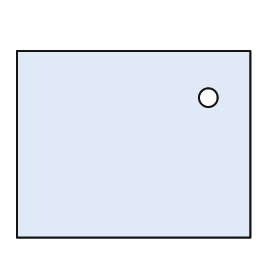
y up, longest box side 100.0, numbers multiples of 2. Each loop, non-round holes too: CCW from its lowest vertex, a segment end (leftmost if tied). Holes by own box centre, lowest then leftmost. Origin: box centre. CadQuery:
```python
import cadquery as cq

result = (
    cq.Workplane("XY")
    .moveTo(-50.0, -40.0)
    .lineTo(50.0, -40.0)
    .lineTo(50.0, 40.0)
    .lineTo(-50.0, 40.0)
    .close()
    .moveTo(32.0, 20.0)
    .circle(4.0)
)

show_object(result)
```